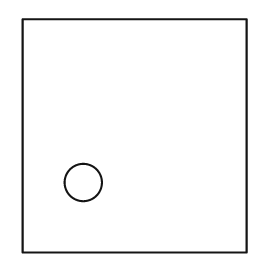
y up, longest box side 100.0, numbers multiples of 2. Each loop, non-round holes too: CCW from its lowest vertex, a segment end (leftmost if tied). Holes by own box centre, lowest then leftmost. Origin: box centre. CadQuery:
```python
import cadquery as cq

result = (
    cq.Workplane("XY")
    .moveTo(-48.0, -50.0)
    .lineTo(48.0, -50.0)
    .lineTo(48.0, 50.0)
    .lineTo(-48.0, 50.0)
    .close()
    .moveTo(-22.0, -20.0)
    .circle(8.0)
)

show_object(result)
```